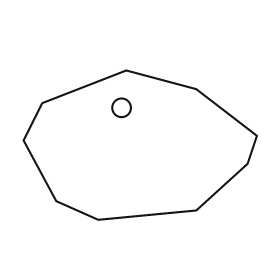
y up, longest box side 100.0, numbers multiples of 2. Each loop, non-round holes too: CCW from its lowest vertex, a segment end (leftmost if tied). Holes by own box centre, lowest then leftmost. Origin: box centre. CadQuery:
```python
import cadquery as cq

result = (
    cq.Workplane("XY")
    .moveTo(-18.0, -32.0)
    .lineTo(24.0, -28.0)
    .lineTo(46.0, -8.0)
    .lineTo(50.0, 4.0)
    .lineTo(24.0, 24.0)
    .lineTo(-6.0, 32.0)
    .lineTo(-42.0, 18.0)
    .lineTo(-50.0, 2.0)
    .lineTo(-36.0, -24.0)
    .close()
    .moveTo(-8.0, 16.0)
    .circle(4.0)
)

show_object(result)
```